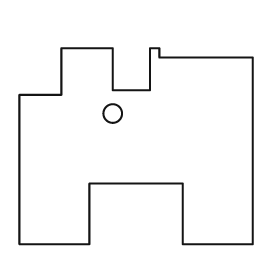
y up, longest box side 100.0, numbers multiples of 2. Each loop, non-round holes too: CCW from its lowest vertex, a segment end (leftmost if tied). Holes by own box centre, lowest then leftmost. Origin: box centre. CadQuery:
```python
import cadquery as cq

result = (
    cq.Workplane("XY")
    .moveTo(-50.0, -42.0)
    .lineTo(-20.0, -42.0)
    .lineTo(-20.0, -16.0)
    .lineTo(20.0, -16.0)
    .lineTo(20.0, -42.0)
    .lineTo(50.0, -42.0)
    .lineTo(50.0, 38.0)
    .lineTo(10.0, 38.0)
    .lineTo(10.0, 42.0)
    .lineTo(6.0, 42.0)
    .lineTo(6.0, 24.0)
    .lineTo(-10.0, 24.0)
    .lineTo(-10.0, 42.0)
    .lineTo(-32.0, 42.0)
    .lineTo(-32.0, 22.0)
    .lineTo(-50.0, 22.0)
    .close()
    .moveTo(-10.0, 14.0)
    .circle(4.0)
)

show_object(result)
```